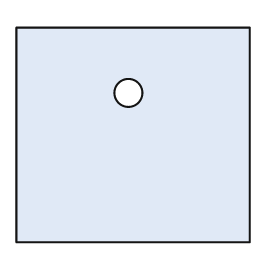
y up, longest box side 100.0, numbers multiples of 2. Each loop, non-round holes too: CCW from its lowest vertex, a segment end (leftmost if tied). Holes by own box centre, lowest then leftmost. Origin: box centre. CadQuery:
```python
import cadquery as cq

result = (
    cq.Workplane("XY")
    .moveTo(-50.0, -46.0)
    .lineTo(50.0, -46.0)
    .lineTo(50.0, 46.0)
    .lineTo(-50.0, 46.0)
    .close()
    .moveTo(-2.0, 18.0)
    .circle(6.0)
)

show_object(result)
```